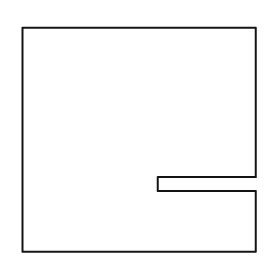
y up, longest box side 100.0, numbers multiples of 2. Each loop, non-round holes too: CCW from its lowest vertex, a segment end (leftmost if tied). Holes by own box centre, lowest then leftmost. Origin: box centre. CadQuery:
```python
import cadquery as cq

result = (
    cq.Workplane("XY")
    .moveTo(-50.0, -48.0)
    .lineTo(50.0, -48.0)
    .lineTo(50.0, -22.0)
    .lineTo(8.0, -22.0)
    .lineTo(8.0, -16.0)
    .lineTo(50.0, -16.0)
    .lineTo(50.0, 48.0)
    .lineTo(-50.0, 48.0)
    .close()
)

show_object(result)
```